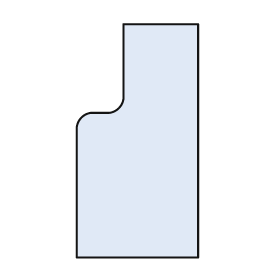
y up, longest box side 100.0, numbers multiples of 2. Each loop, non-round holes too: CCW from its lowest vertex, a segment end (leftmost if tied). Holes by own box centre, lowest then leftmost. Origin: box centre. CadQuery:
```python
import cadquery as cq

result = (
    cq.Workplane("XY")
    .moveTo(-26.0, -50.0)
    .lineTo(26.0, -50.0)
    .lineTo(26.0, 50.0)
    .lineTo(-6.0, 50.0)
    .lineTo(-6.0, 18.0)
    .threePointArc((-8.0, 14.0), (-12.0, 12.0))
    .lineTo(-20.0, 12.0)
    .threePointArc((-24.0, 10.0), (-26.0, 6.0))
    .close()
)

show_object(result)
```